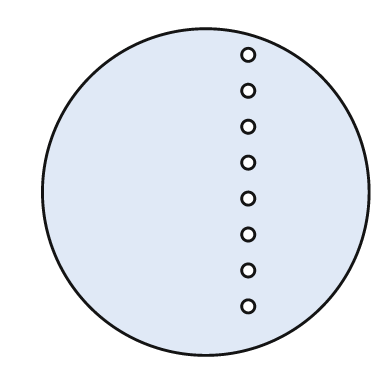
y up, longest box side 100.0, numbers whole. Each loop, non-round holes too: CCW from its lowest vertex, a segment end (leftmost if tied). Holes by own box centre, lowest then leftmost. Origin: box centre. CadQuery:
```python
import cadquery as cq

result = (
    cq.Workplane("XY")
    .moveTo(0.0, 0.0)
    .circle(50.0)
    .moveTo(13.0, -35.0)
    .circle(2.0)
    .moveTo(13.0, -24.0)
    .circle(2.0)
    .moveTo(13.0, -13.0)
    .circle(2.0)
    .moveTo(13.0, -2.0)
    .circle(2.0)
    .moveTo(13.0, 9.0)
    .circle(2.0)
    .moveTo(13.0, 20.0)
    .circle(2.0)
    .moveTo(13.0, 31.0)
    .circle(2.0)
    .moveTo(13.0, 42.0)
    .circle(2.0)
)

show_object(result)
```